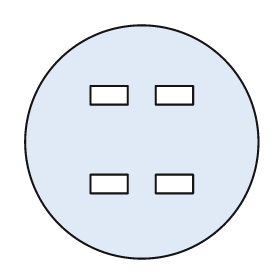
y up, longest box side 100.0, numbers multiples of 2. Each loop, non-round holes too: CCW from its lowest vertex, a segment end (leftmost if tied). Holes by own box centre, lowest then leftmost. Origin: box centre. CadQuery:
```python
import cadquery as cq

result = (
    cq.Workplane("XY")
    .moveTo(0.0, 0.0)
    .circle(50.0)
    .moveTo(-22.0, -22.0)
    .lineTo(-6.0, -22.0)
    .lineTo(-6.0, -14.0)
    .lineTo(-22.0, -14.0)
    .close()
    .moveTo(6.0, -22.0)
    .lineTo(22.0, -22.0)
    .lineTo(22.0, -14.0)
    .lineTo(6.0, -14.0)
    .close()
    .moveTo(-22.0, 16.0)
    .lineTo(-6.0, 16.0)
    .lineTo(-6.0, 24.0)
    .lineTo(-22.0, 24.0)
    .close()
    .moveTo(6.0, 16.0)
    .lineTo(22.0, 16.0)
    .lineTo(22.0, 24.0)
    .lineTo(6.0, 24.0)
    .close()
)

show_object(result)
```